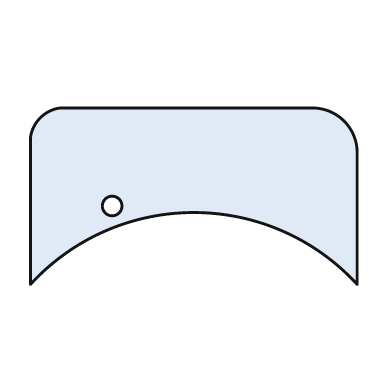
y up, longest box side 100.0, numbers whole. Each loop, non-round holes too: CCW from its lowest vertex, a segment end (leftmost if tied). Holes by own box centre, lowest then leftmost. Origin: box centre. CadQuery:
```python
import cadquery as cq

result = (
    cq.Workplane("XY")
    .moveTo(-50.0, -27.0)
    .threePointArc((0.0, -5.0), (50.0, -27.0))
    .lineTo(50.0, 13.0)
    .threePointArc((46.0, 23.0), (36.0, 27.0))
    .lineTo(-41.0, 27.0)
    .threePointArc((-47.0, 24.0), (-50.0, 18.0))
    .close()
    .moveTo(-25.0, -3.0)
    .circle(3.0)
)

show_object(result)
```